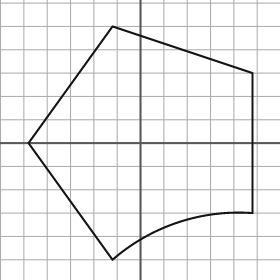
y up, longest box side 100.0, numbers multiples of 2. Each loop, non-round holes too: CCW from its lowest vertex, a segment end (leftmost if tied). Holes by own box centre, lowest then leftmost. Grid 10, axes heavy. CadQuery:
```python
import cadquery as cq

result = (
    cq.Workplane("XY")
    .moveTo(-12.0, -50.0)
    .threePointArc((16.0, -34.0), (48.0, -30.0))
    .lineTo(48.0, 30.0)
    .lineTo(-12.0, 50.0)
    .lineTo(-48.0, 0.0)
    .close()
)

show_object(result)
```